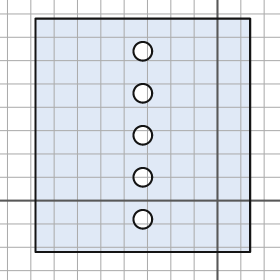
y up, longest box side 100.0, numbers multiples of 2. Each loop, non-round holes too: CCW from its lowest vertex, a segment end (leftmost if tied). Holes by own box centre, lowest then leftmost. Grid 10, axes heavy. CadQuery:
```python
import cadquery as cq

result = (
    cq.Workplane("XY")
    .moveTo(-78.0, -22.0)
    .lineTo(14.0, -22.0)
    .lineTo(14.0, 78.0)
    .lineTo(-78.0, 78.0)
    .close()
    .moveTo(-32.0, -8.0)
    .circle(4.0)
    .moveTo(-32.0, 10.0)
    .circle(4.0)
    .moveTo(-32.0, 28.0)
    .circle(4.0)
    .moveTo(-32.0, 46.0)
    .circle(4.0)
    .moveTo(-32.0, 64.0)
    .circle(4.0)
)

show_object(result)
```